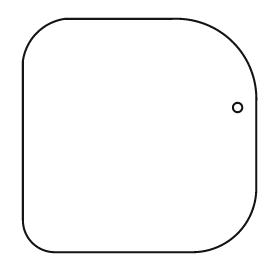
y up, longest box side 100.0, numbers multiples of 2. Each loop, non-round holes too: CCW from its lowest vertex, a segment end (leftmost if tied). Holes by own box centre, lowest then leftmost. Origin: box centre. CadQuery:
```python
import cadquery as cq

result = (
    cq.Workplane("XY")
    .moveTo(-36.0, -50.0)
    .lineTo(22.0, -50.0)
    .threePointArc((42.0, -42.0), (50.0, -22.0))
    .lineTo(50.0, 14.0)
    .threePointArc((40.0, 40.0), (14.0, 50.0))
    .lineTo(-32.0, 50.0)
    .threePointArc((-44.0, 44.0), (-50.0, 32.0))
    .lineTo(-50.0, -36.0)
    .threePointArc((-46.0, -46.0), (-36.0, -50.0))
    .close()
    .moveTo(42.0, 12.0)
    .circle(2.0)
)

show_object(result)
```